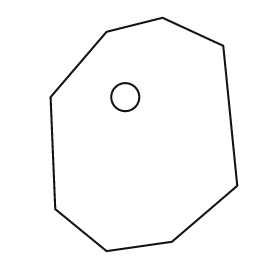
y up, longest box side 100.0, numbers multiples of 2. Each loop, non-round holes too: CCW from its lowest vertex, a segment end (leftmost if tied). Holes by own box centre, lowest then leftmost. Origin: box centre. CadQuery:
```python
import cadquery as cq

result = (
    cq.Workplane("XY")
    .moveTo(-16.0, -50.0)
    .lineTo(12.0, -46.0)
    .lineTo(40.0, -22.0)
    .lineTo(34.0, 38.0)
    .lineTo(8.0, 50.0)
    .lineTo(-16.0, 44.0)
    .lineTo(-40.0, 16.0)
    .lineTo(-38.0, -32.0)
    .close()
    .moveTo(-8.0, 16.0)
    .circle(6.0)
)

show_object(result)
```